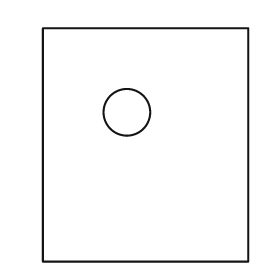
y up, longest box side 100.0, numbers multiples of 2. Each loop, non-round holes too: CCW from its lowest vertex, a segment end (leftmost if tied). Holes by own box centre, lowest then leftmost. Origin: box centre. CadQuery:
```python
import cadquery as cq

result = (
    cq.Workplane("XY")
    .moveTo(-44.0, -50.0)
    .lineTo(44.0, -50.0)
    .lineTo(44.0, 50.0)
    .lineTo(-44.0, 50.0)
    .close()
    .moveTo(-8.0, 14.0)
    .circle(10.0)
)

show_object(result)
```